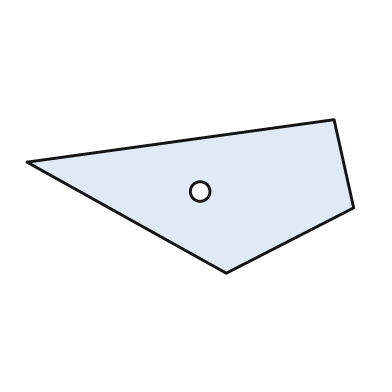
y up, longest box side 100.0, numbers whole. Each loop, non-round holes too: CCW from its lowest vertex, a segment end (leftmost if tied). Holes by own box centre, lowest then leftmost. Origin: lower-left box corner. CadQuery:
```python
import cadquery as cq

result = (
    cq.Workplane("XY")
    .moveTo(61.0, 0.0)
    .lineTo(100.0, 20.0)
    .lineTo(94.0, 47.0)
    .lineTo(0.0, 34.0)
    .close()
    .moveTo(53.0, 25.0)
    .circle(3.0)
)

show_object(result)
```